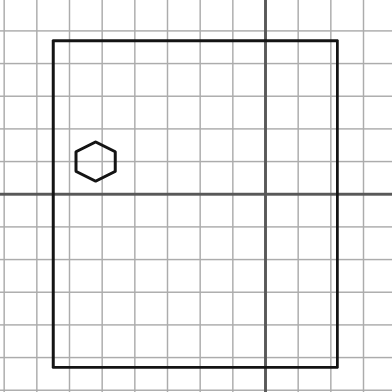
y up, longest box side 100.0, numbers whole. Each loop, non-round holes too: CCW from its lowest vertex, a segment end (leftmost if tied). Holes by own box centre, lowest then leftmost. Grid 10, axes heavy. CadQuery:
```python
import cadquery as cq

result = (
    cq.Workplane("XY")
    .moveTo(-65.0, -53.0)
    .lineTo(22.0, -53.0)
    .lineTo(22.0, 47.0)
    .lineTo(-65.0, 47.0)
    .close()
    .moveTo(-52.0, 4.0)
    .lineTo(-46.0, 7.0)
    .lineTo(-46.0, 13.0)
    .lineTo(-52.0, 16.0)
    .lineTo(-58.0, 13.0)
    .lineTo(-58.0, 7.0)
    .close()
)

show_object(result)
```